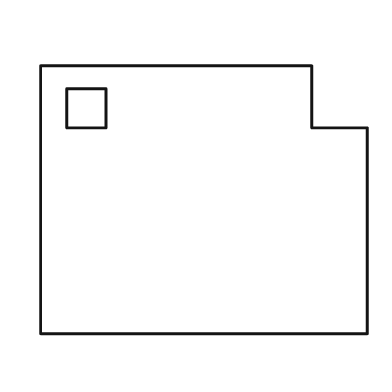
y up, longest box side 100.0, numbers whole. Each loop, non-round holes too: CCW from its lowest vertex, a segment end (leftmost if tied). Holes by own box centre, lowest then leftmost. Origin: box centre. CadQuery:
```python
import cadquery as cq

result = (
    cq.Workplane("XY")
    .moveTo(-50.0, -41.0)
    .lineTo(50.0, -41.0)
    .lineTo(50.0, 22.0)
    .lineTo(33.0, 22.0)
    .lineTo(33.0, 41.0)
    .lineTo(-50.0, 41.0)
    .close()
    .moveTo(-42.0, 22.0)
    .lineTo(-30.0, 22.0)
    .lineTo(-30.0, 34.0)
    .lineTo(-42.0, 34.0)
    .close()
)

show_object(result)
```